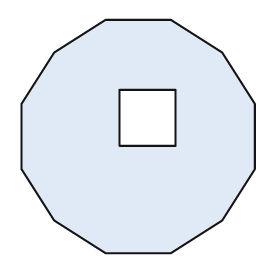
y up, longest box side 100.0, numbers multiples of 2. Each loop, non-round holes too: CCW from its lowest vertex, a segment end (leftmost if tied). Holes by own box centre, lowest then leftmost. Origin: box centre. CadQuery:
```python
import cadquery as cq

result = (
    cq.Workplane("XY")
    .moveTo(-14.0, -50.0)
    .lineTo(14.0, -50.0)
    .lineTo(36.0, -36.0)
    .lineTo(50.0, -14.0)
    .lineTo(50.0, 14.0)
    .lineTo(36.0, 36.0)
    .lineTo(14.0, 50.0)
    .lineTo(-14.0, 50.0)
    .lineTo(-36.0, 36.0)
    .lineTo(-50.0, 14.0)
    .lineTo(-50.0, -14.0)
    .lineTo(-36.0, -36.0)
    .close()
    .moveTo(-8.0, -4.0)
    .lineTo(16.0, -4.0)
    .lineTo(16.0, 20.0)
    .lineTo(-8.0, 20.0)
    .close()
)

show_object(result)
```